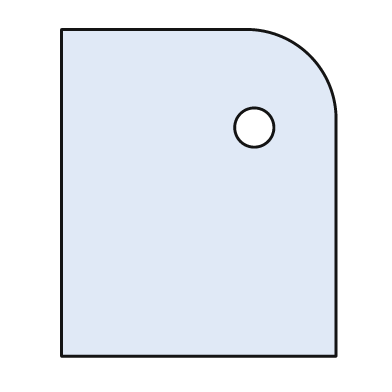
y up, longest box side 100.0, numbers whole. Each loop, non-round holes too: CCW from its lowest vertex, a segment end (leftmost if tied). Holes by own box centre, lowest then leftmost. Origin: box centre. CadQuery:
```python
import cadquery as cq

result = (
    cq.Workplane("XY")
    .moveTo(-42.0, -50.0)
    .lineTo(42.0, -50.0)
    .lineTo(42.0, 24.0)
    .threePointArc((34.0, 42.0), (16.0, 50.0))
    .lineTo(-42.0, 50.0)
    .close()
    .moveTo(17.0, 20.0)
    .circle(6.0)
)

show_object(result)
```